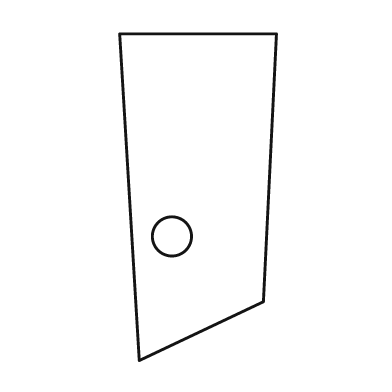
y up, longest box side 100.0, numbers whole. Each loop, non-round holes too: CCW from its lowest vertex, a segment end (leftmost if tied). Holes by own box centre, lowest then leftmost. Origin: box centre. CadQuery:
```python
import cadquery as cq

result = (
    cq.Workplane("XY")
    .moveTo(-18.0, -50.0)
    .lineTo(20.0, -32.0)
    .lineTo(24.0, 50.0)
    .lineTo(-24.0, 50.0)
    .close()
    .moveTo(-8.0, -12.0)
    .circle(6.0)
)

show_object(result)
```